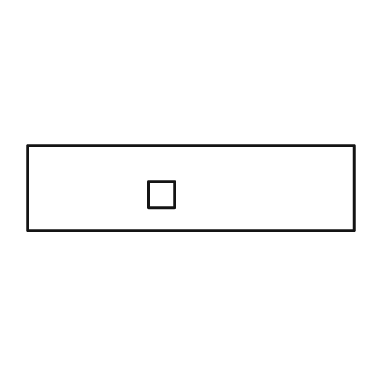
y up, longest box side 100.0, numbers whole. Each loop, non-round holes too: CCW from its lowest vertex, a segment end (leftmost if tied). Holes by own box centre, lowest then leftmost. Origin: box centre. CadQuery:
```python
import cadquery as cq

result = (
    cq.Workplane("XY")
    .moveTo(-50.0, -13.0)
    .lineTo(50.0, -13.0)
    .lineTo(50.0, 13.0)
    .lineTo(-50.0, 13.0)
    .close()
    .moveTo(-13.0, -6.0)
    .lineTo(-5.0, -6.0)
    .lineTo(-5.0, 2.0)
    .lineTo(-13.0, 2.0)
    .close()
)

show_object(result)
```